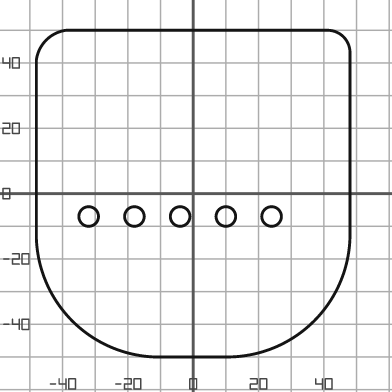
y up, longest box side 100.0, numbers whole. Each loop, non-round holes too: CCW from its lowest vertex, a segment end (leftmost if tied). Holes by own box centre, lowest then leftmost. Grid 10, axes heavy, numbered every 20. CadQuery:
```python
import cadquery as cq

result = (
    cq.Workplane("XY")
    .moveTo(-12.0, -50.0)
    .lineTo(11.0, -50.0)
    .threePointArc((37.0, -39.0), (48.0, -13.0))
    .lineTo(48.0, 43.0)
    .threePointArc((46.0, 48.0), (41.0, 50.0))
    .lineTo(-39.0, 50.0)
    .threePointArc((-45.0, 47.0), (-48.0, 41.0))
    .lineTo(-48.0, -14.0)
    .threePointArc((-37.0, -39.0), (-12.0, -50.0))
    .close()
    .moveTo(-32.0, -7.0)
    .circle(3.0)
    .moveTo(-18.0, -7.0)
    .circle(3.0)
    .moveTo(-4.0, -7.0)
    .circle(3.0)
    .moveTo(10.0, -7.0)
    .circle(3.0)
    .moveTo(24.0, -7.0)
    .circle(3.0)
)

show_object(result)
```